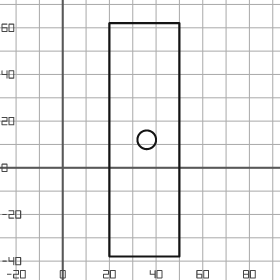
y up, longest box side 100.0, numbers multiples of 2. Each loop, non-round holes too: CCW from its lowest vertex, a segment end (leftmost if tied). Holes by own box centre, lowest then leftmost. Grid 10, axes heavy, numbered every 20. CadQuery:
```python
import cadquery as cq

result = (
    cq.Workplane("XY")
    .moveTo(20.0, -38.0)
    .lineTo(50.0, -38.0)
    .lineTo(50.0, 62.0)
    .lineTo(20.0, 62.0)
    .close()
    .moveTo(36.0, 12.0)
    .circle(4.0)
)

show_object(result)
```